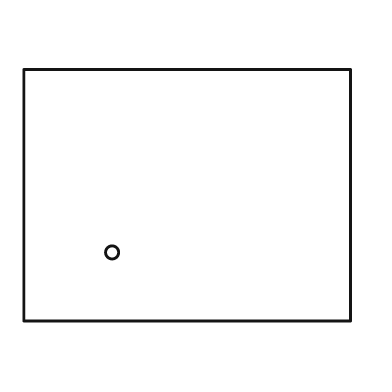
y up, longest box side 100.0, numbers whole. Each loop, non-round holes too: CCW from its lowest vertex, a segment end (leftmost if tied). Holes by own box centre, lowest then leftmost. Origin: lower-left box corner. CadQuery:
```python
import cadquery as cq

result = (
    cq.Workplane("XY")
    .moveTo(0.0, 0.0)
    .lineTo(100.0, 0.0)
    .lineTo(100.0, 77.0)
    .lineTo(0.0, 77.0)
    .close()
    .moveTo(27.0, 21.0)
    .circle(2.0)
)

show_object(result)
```